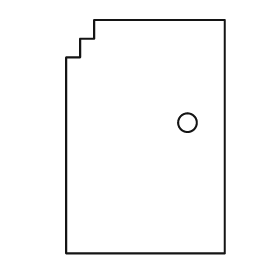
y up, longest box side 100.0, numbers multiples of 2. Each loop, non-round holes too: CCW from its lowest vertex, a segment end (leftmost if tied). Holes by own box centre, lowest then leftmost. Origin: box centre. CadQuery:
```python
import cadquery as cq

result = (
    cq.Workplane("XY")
    .moveTo(-34.0, -50.0)
    .lineTo(34.0, -50.0)
    .lineTo(34.0, 50.0)
    .lineTo(-22.0, 50.0)
    .lineTo(-22.0, 42.0)
    .lineTo(-28.0, 42.0)
    .lineTo(-28.0, 34.0)
    .lineTo(-34.0, 34.0)
    .close()
    .moveTo(18.0, 6.0)
    .circle(4.0)
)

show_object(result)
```